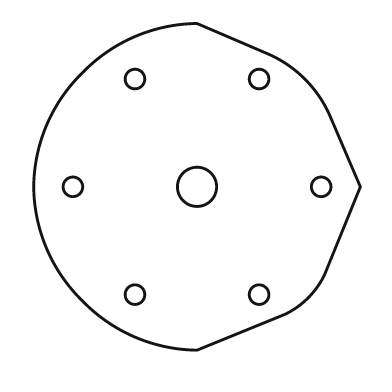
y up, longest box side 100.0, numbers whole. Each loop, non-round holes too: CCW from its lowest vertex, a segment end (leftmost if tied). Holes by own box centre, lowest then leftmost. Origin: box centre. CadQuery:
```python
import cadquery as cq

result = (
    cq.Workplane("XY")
    .moveTo(0.0, -50.0)
    .lineTo(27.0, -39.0)
    .threePointArc((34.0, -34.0), (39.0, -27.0))
    .lineTo(50.0, 0.0)
    .lineTo(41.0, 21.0)
    .threePointArc((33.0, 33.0), (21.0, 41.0))
    .lineTo(0.0, 50.0)
    .threePointArc((-19.0, 46.0), (-35.0, 35.0))
    .threePointArc((-46.0, 19.0), (-50.0, 0.0))
    .threePointArc((-46.0, -19.0), (-35.0, -35.0))
    .threePointArc((-19.0, -46.0), (0.0, -50.0))
    .close()
    .moveTo(-19.0, -33.0)
    .circle(3.0)
    .moveTo(19.0, -33.0)
    .circle(3.0)
    .moveTo(-38.0, 0.0)
    .circle(3.0)
    .moveTo(0.0, 0.0)
    .circle(6.0)
    .moveTo(38.0, 0.0)
    .circle(3.0)
    .moveTo(-19.0, 33.0)
    .circle(3.0)
    .moveTo(19.0, 33.0)
    .circle(3.0)
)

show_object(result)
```